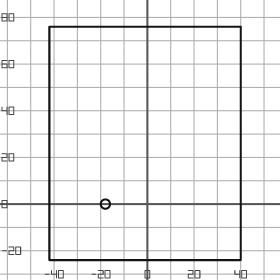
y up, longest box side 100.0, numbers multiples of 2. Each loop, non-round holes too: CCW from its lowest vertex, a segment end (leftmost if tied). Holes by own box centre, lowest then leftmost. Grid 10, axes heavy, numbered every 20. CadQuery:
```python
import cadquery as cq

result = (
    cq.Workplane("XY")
    .moveTo(-42.0, -24.0)
    .lineTo(40.0, -24.0)
    .lineTo(40.0, 76.0)
    .lineTo(-42.0, 76.0)
    .close()
    .moveTo(-18.0, 0.0)
    .circle(2.0)
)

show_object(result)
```